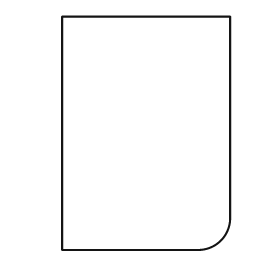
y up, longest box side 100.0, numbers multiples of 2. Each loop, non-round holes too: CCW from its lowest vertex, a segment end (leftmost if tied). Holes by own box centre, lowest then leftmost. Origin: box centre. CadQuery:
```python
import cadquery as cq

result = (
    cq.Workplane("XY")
    .moveTo(-36.0, -50.0)
    .lineTo(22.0, -50.0)
    .threePointArc((32.0, -46.0), (36.0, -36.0))
    .lineTo(36.0, 50.0)
    .lineTo(-36.0, 50.0)
    .close()
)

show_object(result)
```